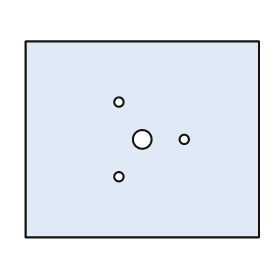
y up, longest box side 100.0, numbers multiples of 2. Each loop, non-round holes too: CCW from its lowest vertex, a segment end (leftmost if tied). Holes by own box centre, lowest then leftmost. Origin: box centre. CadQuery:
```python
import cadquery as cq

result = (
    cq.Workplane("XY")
    .moveTo(-50.0, -42.0)
    .lineTo(50.0, -42.0)
    .lineTo(50.0, 42.0)
    .lineTo(-50.0, 42.0)
    .close()
    .moveTo(-10.0, -16.0)
    .circle(2.0)
    .moveTo(0.0, 0.0)
    .circle(4.0)
    .moveTo(18.0, 0.0)
    .circle(2.0)
    .moveTo(-10.0, 16.0)
    .circle(2.0)
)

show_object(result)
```